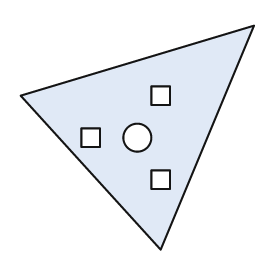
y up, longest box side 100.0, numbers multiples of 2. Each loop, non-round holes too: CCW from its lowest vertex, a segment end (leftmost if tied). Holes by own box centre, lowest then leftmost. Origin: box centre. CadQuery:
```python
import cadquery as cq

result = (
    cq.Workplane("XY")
    .moveTo(10.0, -48.0)
    .lineTo(50.0, 48.0)
    .lineTo(-50.0, 18.0)
    .close()
    .moveTo(6.0, -22.0)
    .lineTo(14.0, -22.0)
    .lineTo(14.0, -14.0)
    .lineTo(6.0, -14.0)
    .close()
    .moveTo(-24.0, -4.0)
    .lineTo(-16.0, -4.0)
    .lineTo(-16.0, 4.0)
    .lineTo(-24.0, 4.0)
    .close()
    .moveTo(0.0, 0.0)
    .circle(6.0)
    .moveTo(6.0, 14.0)
    .lineTo(14.0, 14.0)
    .lineTo(14.0, 22.0)
    .lineTo(6.0, 22.0)
    .close()
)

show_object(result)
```